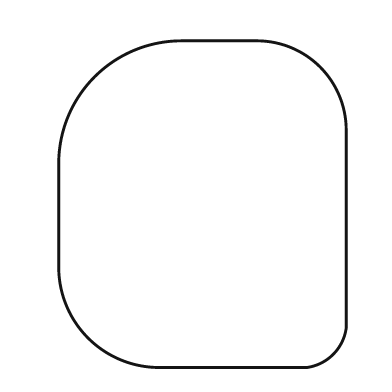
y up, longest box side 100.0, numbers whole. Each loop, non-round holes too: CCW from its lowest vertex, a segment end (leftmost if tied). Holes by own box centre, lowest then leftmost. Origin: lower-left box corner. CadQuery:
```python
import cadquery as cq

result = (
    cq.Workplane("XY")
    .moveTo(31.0, 0.0)
    .lineTo(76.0, 0.0)
    .threePointArc((84.0, 4.0), (88.0, 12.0))
    .lineTo(88.0, 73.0)
    .threePointArc((80.0, 92.0), (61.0, 100.0))
    .lineTo(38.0, 100.0)
    .threePointArc((11.0, 89.0), (0.0, 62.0))
    .lineTo(0.0, 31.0)
    .threePointArc((9.0, 9.0), (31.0, 0.0))
    .close()
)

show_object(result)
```